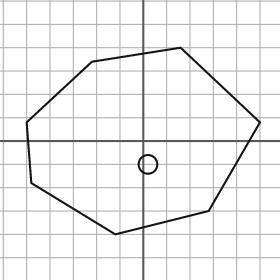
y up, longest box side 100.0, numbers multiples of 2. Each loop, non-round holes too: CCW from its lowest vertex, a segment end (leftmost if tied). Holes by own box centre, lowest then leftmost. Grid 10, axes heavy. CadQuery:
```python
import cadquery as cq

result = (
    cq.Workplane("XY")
    .moveTo(-12.0, -40.0)
    .lineTo(28.0, -30.0)
    .lineTo(50.0, 8.0)
    .lineTo(16.0, 40.0)
    .lineTo(-22.0, 34.0)
    .lineTo(-50.0, 8.0)
    .lineTo(-48.0, -18.0)
    .close()
    .moveTo(2.0, -10.0)
    .circle(4.0)
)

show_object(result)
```